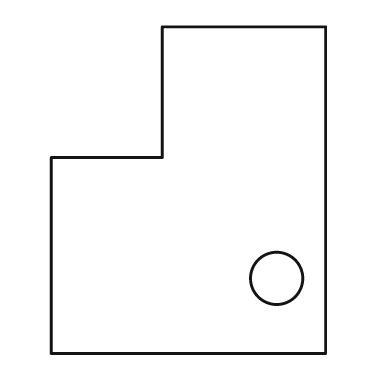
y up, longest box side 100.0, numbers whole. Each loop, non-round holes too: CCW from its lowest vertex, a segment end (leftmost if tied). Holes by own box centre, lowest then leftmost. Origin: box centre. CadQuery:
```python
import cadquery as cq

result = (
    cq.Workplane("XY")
    .moveTo(-42.0, -50.0)
    .lineTo(42.0, -50.0)
    .lineTo(42.0, 50.0)
    .lineTo(-8.0, 50.0)
    .lineTo(-8.0, 10.0)
    .lineTo(-42.0, 10.0)
    .close()
    .moveTo(27.0, -27.0)
    .circle(8.0)
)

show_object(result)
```